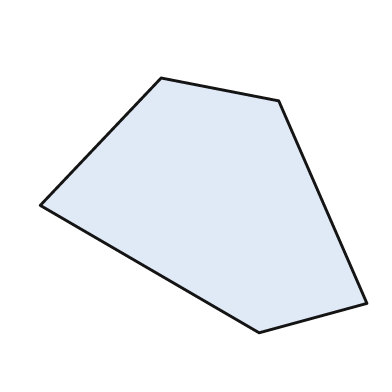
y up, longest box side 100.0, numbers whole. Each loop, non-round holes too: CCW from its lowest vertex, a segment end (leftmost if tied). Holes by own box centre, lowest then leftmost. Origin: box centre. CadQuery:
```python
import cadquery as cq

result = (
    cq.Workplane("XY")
    .moveTo(17.0, -39.0)
    .lineTo(50.0, -30.0)
    .lineTo(23.0, 32.0)
    .lineTo(-13.0, 39.0)
    .lineTo(-50.0, 0.0)
    .close()
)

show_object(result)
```